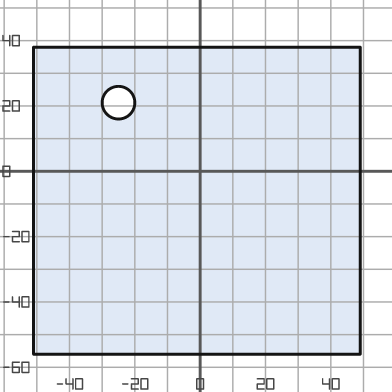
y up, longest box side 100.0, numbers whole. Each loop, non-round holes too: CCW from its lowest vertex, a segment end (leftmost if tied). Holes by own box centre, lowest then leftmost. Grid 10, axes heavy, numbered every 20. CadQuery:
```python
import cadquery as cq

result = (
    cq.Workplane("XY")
    .moveTo(-51.0, -56.0)
    .lineTo(49.0, -56.0)
    .lineTo(49.0, 38.0)
    .lineTo(-51.0, 38.0)
    .close()
    .moveTo(-25.0, 21.0)
    .circle(5.0)
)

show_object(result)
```